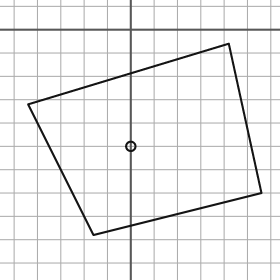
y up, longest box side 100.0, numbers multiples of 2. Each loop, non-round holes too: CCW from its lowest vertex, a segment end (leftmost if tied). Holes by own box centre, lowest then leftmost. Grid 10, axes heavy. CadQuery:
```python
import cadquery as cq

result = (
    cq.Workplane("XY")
    .moveTo(-16.0, -88.0)
    .lineTo(56.0, -70.0)
    .lineTo(42.0, -6.0)
    .lineTo(-44.0, -32.0)
    .close()
    .moveTo(0.0, -50.0)
    .circle(2.0)
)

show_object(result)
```